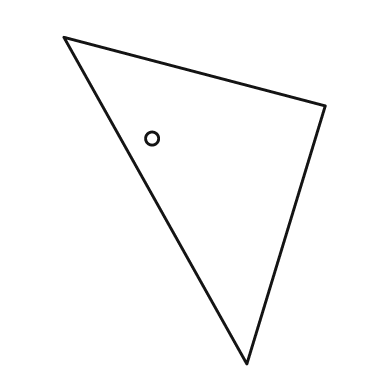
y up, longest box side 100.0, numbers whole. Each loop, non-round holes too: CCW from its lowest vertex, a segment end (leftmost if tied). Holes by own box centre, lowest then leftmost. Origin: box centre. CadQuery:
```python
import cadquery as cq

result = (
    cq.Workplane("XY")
    .moveTo(16.0, -50.0)
    .lineTo(40.0, 29.0)
    .lineTo(-40.0, 50.0)
    .close()
    .moveTo(-13.0, 19.0)
    .circle(2.0)
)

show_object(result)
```